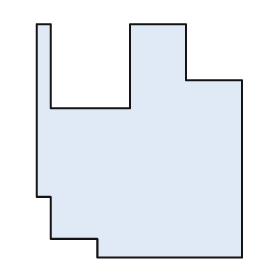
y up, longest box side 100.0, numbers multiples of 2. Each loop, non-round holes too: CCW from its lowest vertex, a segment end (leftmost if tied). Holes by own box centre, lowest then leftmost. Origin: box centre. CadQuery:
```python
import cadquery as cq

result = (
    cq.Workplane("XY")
    .moveTo(-18.0, -50.0)
    .lineTo(44.0, -50.0)
    .lineTo(44.0, 26.0)
    .lineTo(20.0, 26.0)
    .lineTo(20.0, 50.0)
    .lineTo(-4.0, 50.0)
    .lineTo(-4.0, 14.0)
    .lineTo(-38.0, 14.0)
    .lineTo(-38.0, 50.0)
    .lineTo(-44.0, 50.0)
    .lineTo(-44.0, -24.0)
    .lineTo(-38.0, -24.0)
    .lineTo(-38.0, -42.0)
    .lineTo(-18.0, -42.0)
    .close()
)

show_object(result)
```